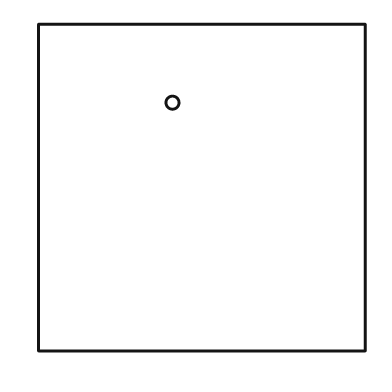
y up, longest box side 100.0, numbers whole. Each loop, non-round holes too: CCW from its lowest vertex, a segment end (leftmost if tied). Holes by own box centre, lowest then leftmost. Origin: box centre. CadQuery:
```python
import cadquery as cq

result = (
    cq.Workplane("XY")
    .moveTo(-50.0, -50.0)
    .lineTo(50.0, -50.0)
    .lineTo(50.0, 50.0)
    .lineTo(-50.0, 50.0)
    .close()
    .moveTo(-9.0, 26.0)
    .circle(2.0)
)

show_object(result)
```